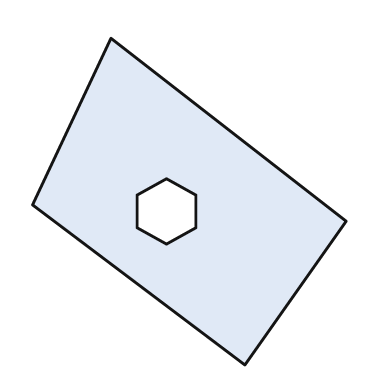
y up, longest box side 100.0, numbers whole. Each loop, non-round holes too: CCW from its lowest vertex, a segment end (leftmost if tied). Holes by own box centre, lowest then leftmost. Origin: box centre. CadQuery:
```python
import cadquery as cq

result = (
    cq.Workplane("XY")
    .moveTo(17.0, -50.0)
    .lineTo(48.0, -6.0)
    .lineTo(-24.0, 50.0)
    .lineTo(-48.0, -1.0)
    .close()
    .moveTo(-7.0, -13.0)
    .lineTo(2.0, -8.0)
    .lineTo(2.0, 2.0)
    .lineTo(-7.0, 7.0)
    .lineTo(-16.0, 2.0)
    .lineTo(-16.0, -8.0)
    .close()
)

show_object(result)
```